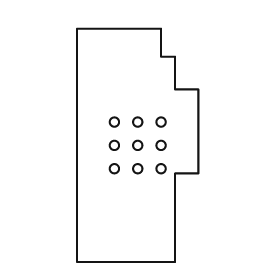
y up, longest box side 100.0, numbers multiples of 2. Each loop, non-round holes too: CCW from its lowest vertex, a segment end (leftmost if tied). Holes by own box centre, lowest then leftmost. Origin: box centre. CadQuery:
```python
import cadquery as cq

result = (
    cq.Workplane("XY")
    .moveTo(-26.0, -50.0)
    .lineTo(16.0, -50.0)
    .lineTo(16.0, -12.0)
    .lineTo(26.0, -12.0)
    .lineTo(26.0, 24.0)
    .lineTo(16.0, 24.0)
    .lineTo(16.0, 38.0)
    .lineTo(10.0, 38.0)
    .lineTo(10.0, 50.0)
    .lineTo(-26.0, 50.0)
    .close()
    .moveTo(-10.0, -10.0)
    .circle(2.0)
    .moveTo(0.0, -10.0)
    .circle(2.0)
    .moveTo(10.0, -10.0)
    .circle(2.0)
    .moveTo(-10.0, 0.0)
    .circle(2.0)
    .moveTo(0.0, 0.0)
    .circle(2.0)
    .moveTo(10.0, 0.0)
    .circle(2.0)
    .moveTo(-10.0, 10.0)
    .circle(2.0)
    .moveTo(0.0, 10.0)
    .circle(2.0)
    .moveTo(10.0, 10.0)
    .circle(2.0)
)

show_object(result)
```